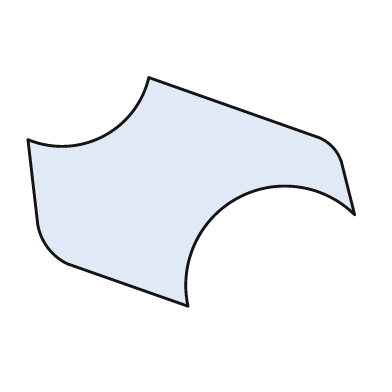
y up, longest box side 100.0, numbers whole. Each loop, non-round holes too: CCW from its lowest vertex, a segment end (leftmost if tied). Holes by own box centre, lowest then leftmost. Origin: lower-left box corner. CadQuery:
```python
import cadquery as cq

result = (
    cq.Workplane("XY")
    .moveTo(49.0, 0.0)
    .threePointArc((64.0, 33.0), (100.0, 28.0))
    .lineTo(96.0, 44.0)
    .threePointArc((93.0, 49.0), (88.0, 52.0))
    .lineTo(37.0, 70.0)
    .threePointArc((23.0, 52.0), (0.0, 51.0))
    .lineTo(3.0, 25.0)
    .threePointArc((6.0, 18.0), (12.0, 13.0))
    .close()
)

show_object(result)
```